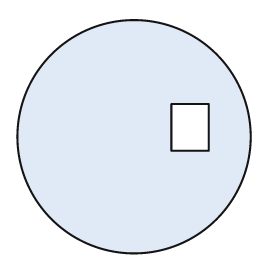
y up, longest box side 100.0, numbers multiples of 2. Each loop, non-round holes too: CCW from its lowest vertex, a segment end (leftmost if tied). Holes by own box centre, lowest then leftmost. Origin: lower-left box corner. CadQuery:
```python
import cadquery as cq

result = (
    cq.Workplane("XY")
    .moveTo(50.0, 50.0)
    .circle(50.0)
    .moveTo(66.0, 44.0)
    .lineTo(82.0, 44.0)
    .lineTo(82.0, 64.0)
    .lineTo(66.0, 64.0)
    .close()
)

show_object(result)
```